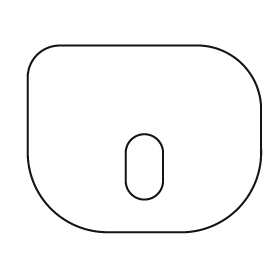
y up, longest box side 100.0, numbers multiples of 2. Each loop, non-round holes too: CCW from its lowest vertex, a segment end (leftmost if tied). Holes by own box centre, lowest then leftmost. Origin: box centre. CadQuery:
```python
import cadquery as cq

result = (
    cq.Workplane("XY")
    .moveTo(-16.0, -40.0)
    .lineTo(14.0, -40.0)
    .threePointArc((40.0, -30.0), (50.0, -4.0))
    .lineTo(50.0, 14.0)
    .threePointArc((42.0, 32.0), (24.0, 40.0))
    .lineTo(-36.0, 40.0)
    .threePointArc((-46.0, 36.0), (-50.0, 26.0))
    .lineTo(-50.0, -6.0)
    .threePointArc((-40.0, -30.0), (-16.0, -40.0))
    .close()
    .moveTo(-8.0, -18.0)
    .threePointArc((0.0, -26.0), (8.0, -18.0))
    .lineTo(8.0, -6.0)
    .threePointArc((0.0, 2.0), (-8.0, -6.0))
    .close()
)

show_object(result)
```